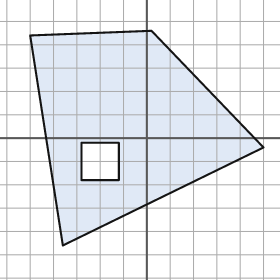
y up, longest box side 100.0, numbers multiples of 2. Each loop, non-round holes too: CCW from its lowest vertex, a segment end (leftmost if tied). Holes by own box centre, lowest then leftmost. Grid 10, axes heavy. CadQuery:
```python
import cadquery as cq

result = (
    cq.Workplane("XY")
    .moveTo(-36.0, -46.0)
    .lineTo(50.0, -4.0)
    .lineTo(2.0, 46.0)
    .lineTo(-50.0, 44.0)
    .close()
    .moveTo(-28.0, -18.0)
    .lineTo(-12.0, -18.0)
    .lineTo(-12.0, -2.0)
    .lineTo(-28.0, -2.0)
    .close()
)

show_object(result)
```